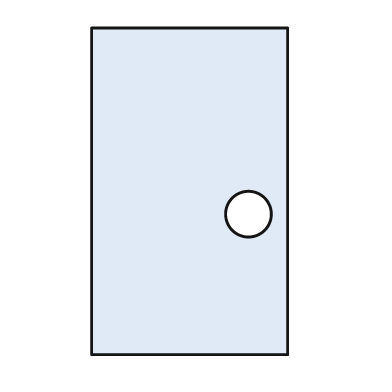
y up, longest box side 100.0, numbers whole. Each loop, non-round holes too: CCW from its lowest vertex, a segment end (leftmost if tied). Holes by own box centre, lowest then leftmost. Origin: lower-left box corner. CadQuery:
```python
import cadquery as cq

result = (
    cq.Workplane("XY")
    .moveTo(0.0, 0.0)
    .lineTo(60.0, 0.0)
    .lineTo(60.0, 100.0)
    .lineTo(0.0, 100.0)
    .close()
    .moveTo(48.0, 43.0)
    .circle(7.0)
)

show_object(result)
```